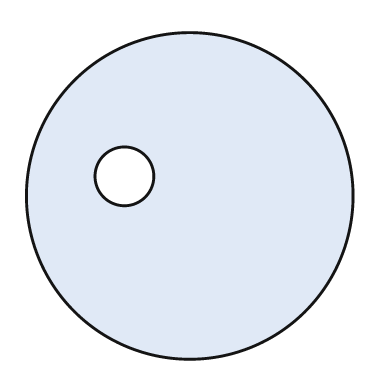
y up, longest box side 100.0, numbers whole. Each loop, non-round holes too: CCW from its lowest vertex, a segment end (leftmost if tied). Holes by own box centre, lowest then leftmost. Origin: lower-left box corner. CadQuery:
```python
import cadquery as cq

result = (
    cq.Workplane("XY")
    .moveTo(50.0, 50.0)
    .circle(50.0)
    .moveTo(30.0, 56.0)
    .circle(9.0)
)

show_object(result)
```